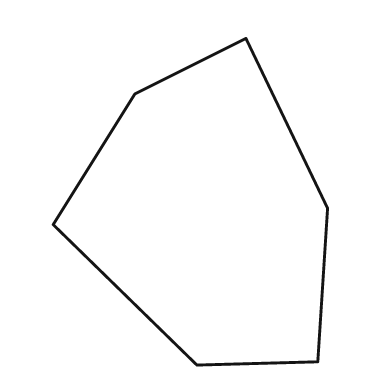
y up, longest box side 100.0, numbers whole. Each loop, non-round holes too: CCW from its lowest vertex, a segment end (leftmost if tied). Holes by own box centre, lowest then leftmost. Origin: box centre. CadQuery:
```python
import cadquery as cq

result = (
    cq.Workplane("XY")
    .moveTo(2.0, -50.0)
    .lineTo(39.0, -49.0)
    .lineTo(42.0, -2.0)
    .lineTo(17.0, 50.0)
    .lineTo(-17.0, 33.0)
    .lineTo(-42.0, -7.0)
    .close()
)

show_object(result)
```